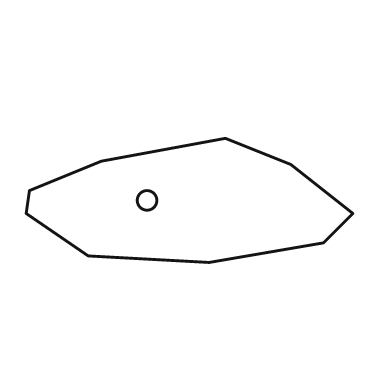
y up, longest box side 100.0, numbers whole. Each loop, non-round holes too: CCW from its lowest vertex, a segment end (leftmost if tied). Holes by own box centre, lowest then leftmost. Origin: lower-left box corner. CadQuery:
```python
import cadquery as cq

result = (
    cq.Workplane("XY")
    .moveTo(56.0, 0.0)
    .lineTo(91.0, 6.0)
    .lineTo(100.0, 15.0)
    .lineTo(81.0, 30.0)
    .lineTo(61.0, 38.0)
    .lineTo(23.0, 31.0)
    .lineTo(1.0, 22.0)
    .lineTo(0.0, 15.0)
    .lineTo(19.0, 2.0)
    .close()
    .moveTo(37.0, 19.0)
    .circle(3.0)
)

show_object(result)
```